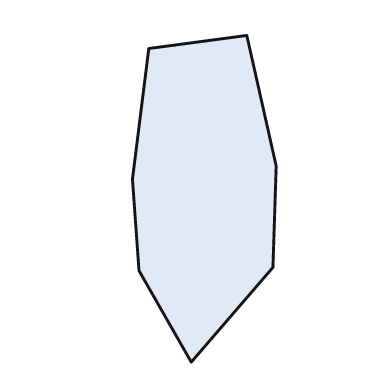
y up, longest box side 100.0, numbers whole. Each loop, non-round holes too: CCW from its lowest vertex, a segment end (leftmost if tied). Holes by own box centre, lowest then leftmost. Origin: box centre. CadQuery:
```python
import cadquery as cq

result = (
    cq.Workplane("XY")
    .moveTo(-4.0, -50.0)
    .lineTo(21.0, -21.0)
    .lineTo(22.0, 10.0)
    .lineTo(13.0, 50.0)
    .lineTo(-17.0, 46.0)
    .lineTo(-22.0, 6.0)
    .lineTo(-20.0, -22.0)
    .close()
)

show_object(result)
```